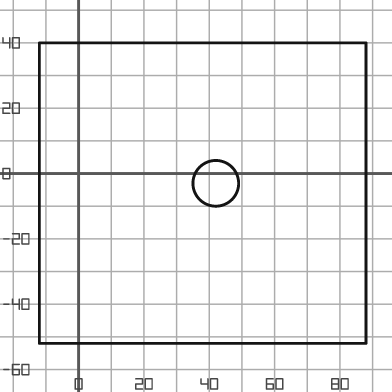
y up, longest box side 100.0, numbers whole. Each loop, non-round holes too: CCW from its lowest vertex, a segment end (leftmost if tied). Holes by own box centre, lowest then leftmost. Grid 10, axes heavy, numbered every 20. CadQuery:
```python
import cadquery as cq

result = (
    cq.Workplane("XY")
    .moveTo(-12.0, -52.0)
    .lineTo(88.0, -52.0)
    .lineTo(88.0, 40.0)
    .lineTo(-12.0, 40.0)
    .close()
    .moveTo(42.0, -3.0)
    .circle(7.0)
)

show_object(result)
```